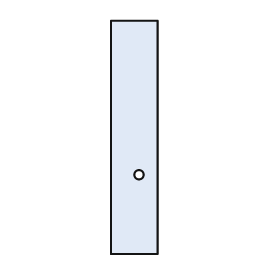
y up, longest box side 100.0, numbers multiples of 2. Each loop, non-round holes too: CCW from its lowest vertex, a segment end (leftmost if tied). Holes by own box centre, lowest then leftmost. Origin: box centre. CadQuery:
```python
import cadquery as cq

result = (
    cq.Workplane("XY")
    .moveTo(-10.0, -50.0)
    .lineTo(10.0, -50.0)
    .lineTo(10.0, 50.0)
    .lineTo(-10.0, 50.0)
    .close()
    .moveTo(2.0, -16.0)
    .circle(2.0)
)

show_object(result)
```